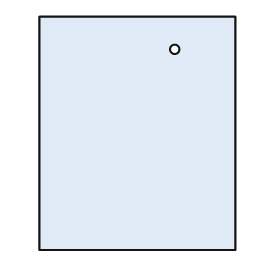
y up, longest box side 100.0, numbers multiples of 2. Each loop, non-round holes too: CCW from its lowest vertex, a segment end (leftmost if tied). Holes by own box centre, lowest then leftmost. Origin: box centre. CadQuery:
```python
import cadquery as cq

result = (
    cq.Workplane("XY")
    .moveTo(-42.0, -50.0)
    .lineTo(42.0, -50.0)
    .lineTo(42.0, 50.0)
    .lineTo(-42.0, 50.0)
    .close()
    .moveTo(16.0, 36.0)
    .circle(2.0)
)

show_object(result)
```